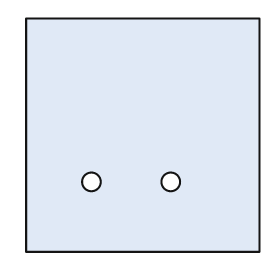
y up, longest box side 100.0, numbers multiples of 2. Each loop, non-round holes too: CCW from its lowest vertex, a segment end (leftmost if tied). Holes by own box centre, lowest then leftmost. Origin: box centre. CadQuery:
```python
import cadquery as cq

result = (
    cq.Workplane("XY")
    .moveTo(-50.0, -50.0)
    .lineTo(50.0, -50.0)
    .lineTo(50.0, 50.0)
    .lineTo(-50.0, 50.0)
    .close()
    .moveTo(-22.0, -20.0)
    .circle(4.0)
    .moveTo(12.0, -20.0)
    .circle(4.0)
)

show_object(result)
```